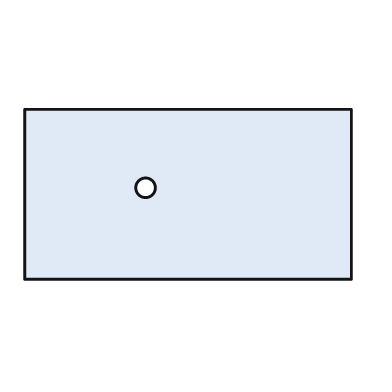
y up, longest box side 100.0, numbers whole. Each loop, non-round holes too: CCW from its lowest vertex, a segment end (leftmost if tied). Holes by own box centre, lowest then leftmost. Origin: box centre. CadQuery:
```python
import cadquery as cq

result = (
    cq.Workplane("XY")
    .moveTo(-50.0, -26.0)
    .lineTo(50.0, -26.0)
    .lineTo(50.0, 26.0)
    .lineTo(-50.0, 26.0)
    .close()
    .moveTo(-13.0, 2.0)
    .circle(3.0)
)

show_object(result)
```